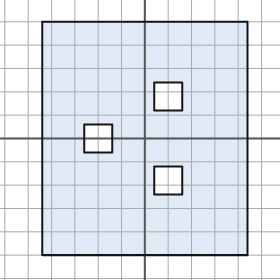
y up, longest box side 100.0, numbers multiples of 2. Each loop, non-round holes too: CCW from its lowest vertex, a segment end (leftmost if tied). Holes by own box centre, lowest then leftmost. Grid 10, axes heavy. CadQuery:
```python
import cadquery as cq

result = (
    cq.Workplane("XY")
    .moveTo(-44.0, -50.0)
    .lineTo(44.0, -50.0)
    .lineTo(44.0, 50.0)
    .lineTo(-44.0, 50.0)
    .close()
    .moveTo(4.0, -24.0)
    .lineTo(16.0, -24.0)
    .lineTo(16.0, -12.0)
    .lineTo(4.0, -12.0)
    .close()
    .moveTo(-26.0, -6.0)
    .lineTo(-14.0, -6.0)
    .lineTo(-14.0, 6.0)
    .lineTo(-26.0, 6.0)
    .close()
    .moveTo(4.0, 12.0)
    .lineTo(16.0, 12.0)
    .lineTo(16.0, 24.0)
    .lineTo(4.0, 24.0)
    .close()
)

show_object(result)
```